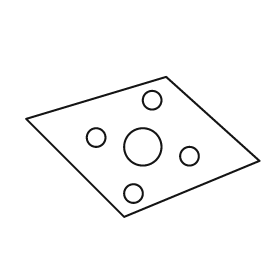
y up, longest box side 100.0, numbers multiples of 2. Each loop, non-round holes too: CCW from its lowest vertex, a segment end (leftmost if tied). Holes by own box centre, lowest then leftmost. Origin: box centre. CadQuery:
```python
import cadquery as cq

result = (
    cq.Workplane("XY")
    .moveTo(-8.0, -30.0)
    .lineTo(50.0, -6.0)
    .lineTo(10.0, 30.0)
    .lineTo(-50.0, 12.0)
    .close()
    .moveTo(-4.0, -20.0)
    .circle(4.0)
    .moveTo(20.0, -4.0)
    .circle(4.0)
    .moveTo(0.0, 0.0)
    .circle(8.0)
    .moveTo(-20.0, 4.0)
    .circle(4.0)
    .moveTo(4.0, 20.0)
    .circle(4.0)
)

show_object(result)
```